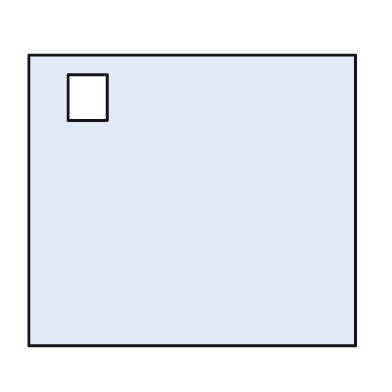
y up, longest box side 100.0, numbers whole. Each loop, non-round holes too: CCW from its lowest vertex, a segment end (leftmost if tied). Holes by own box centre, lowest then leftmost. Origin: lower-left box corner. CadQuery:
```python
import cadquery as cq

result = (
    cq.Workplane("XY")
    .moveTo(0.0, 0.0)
    .lineTo(100.0, 0.0)
    .lineTo(100.0, 89.0)
    .lineTo(0.0, 89.0)
    .close()
    .moveTo(12.0, 69.0)
    .lineTo(24.0, 69.0)
    .lineTo(24.0, 83.0)
    .lineTo(12.0, 83.0)
    .close()
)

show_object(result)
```